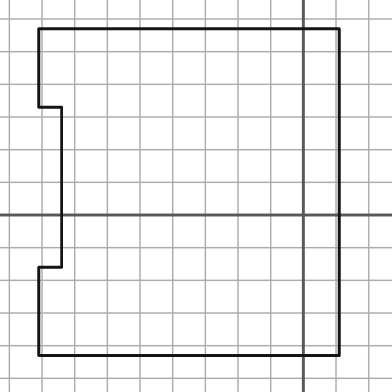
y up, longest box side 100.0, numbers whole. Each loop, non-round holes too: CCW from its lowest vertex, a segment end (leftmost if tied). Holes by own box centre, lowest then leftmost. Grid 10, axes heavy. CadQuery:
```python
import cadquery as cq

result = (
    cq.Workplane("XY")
    .moveTo(-81.0, -43.0)
    .lineTo(11.0, -43.0)
    .lineTo(11.0, 57.0)
    .lineTo(-81.0, 57.0)
    .lineTo(-81.0, 33.0)
    .lineTo(-74.0, 33.0)
    .lineTo(-74.0, -16.0)
    .lineTo(-81.0, -16.0)
    .close()
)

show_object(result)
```